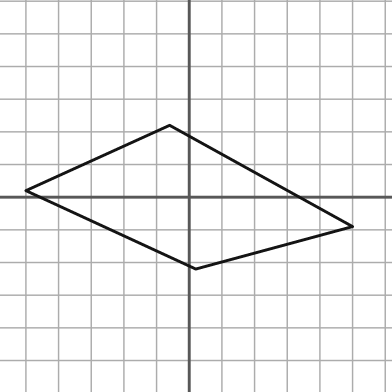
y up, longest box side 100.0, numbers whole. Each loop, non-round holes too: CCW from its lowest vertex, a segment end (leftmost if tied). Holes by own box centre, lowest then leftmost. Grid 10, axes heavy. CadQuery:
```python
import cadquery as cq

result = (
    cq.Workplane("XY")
    .moveTo(2.0, -22.0)
    .lineTo(50.0, -9.0)
    .lineTo(-6.0, 22.0)
    .lineTo(-50.0, 2.0)
    .close()
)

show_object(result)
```